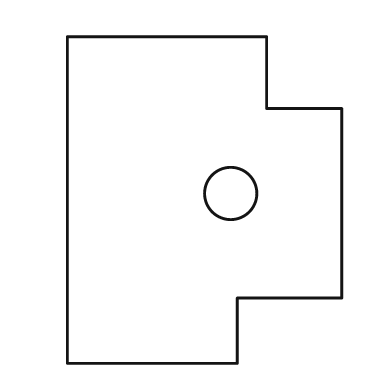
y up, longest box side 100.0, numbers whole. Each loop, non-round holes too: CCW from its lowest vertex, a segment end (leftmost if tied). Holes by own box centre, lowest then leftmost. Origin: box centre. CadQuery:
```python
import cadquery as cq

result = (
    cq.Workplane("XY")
    .moveTo(-42.0, -50.0)
    .lineTo(10.0, -50.0)
    .lineTo(10.0, -30.0)
    .lineTo(42.0, -30.0)
    .lineTo(42.0, 28.0)
    .lineTo(19.0, 28.0)
    .lineTo(19.0, 50.0)
    .lineTo(-42.0, 50.0)
    .close()
    .moveTo(8.0, 2.0)
    .circle(8.0)
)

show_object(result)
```